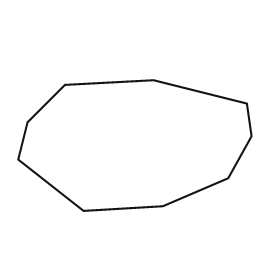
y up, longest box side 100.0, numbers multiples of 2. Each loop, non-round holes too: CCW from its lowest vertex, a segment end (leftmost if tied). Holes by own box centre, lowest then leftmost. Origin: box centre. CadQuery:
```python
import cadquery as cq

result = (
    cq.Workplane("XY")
    .moveTo(-22.0, -28.0)
    .lineTo(12.0, -26.0)
    .lineTo(40.0, -14.0)
    .lineTo(50.0, 4.0)
    .lineTo(48.0, 18.0)
    .lineTo(8.0, 28.0)
    .lineTo(-30.0, 26.0)
    .lineTo(-46.0, 10.0)
    .lineTo(-50.0, -6.0)
    .close()
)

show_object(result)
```